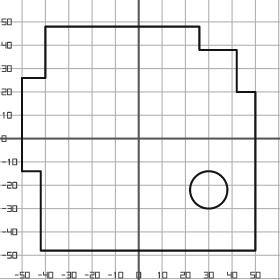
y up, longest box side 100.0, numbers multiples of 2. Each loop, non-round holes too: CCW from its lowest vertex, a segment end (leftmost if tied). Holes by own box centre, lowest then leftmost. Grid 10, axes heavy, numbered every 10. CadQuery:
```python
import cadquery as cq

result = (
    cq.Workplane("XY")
    .moveTo(-42.0, -48.0)
    .lineTo(50.0, -48.0)
    .lineTo(50.0, 20.0)
    .lineTo(42.0, 20.0)
    .lineTo(42.0, 38.0)
    .lineTo(26.0, 38.0)
    .lineTo(26.0, 48.0)
    .lineTo(-40.0, 48.0)
    .lineTo(-40.0, 26.0)
    .lineTo(-50.0, 26.0)
    .lineTo(-50.0, -14.0)
    .lineTo(-42.0, -14.0)
    .close()
    .moveTo(30.0, -22.0)
    .circle(8.0)
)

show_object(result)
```